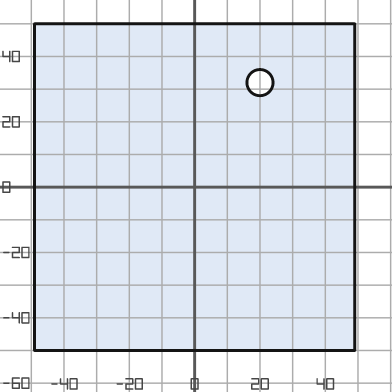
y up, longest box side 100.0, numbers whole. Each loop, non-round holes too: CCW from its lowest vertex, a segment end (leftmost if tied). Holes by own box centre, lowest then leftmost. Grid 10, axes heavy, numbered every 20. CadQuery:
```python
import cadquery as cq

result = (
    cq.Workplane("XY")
    .moveTo(-49.0, -50.0)
    .lineTo(49.0, -50.0)
    .lineTo(49.0, 50.0)
    .lineTo(-49.0, 50.0)
    .close()
    .moveTo(20.0, 32.0)
    .circle(4.0)
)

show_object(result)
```